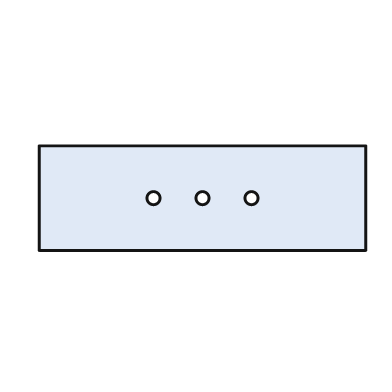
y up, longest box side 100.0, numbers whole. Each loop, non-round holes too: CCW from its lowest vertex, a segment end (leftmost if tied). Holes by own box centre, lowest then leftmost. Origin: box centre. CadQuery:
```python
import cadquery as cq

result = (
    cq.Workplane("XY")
    .moveTo(-50.0, -16.0)
    .lineTo(50.0, -16.0)
    .lineTo(50.0, 16.0)
    .lineTo(-50.0, 16.0)
    .close()
    .moveTo(-15.0, 0.0)
    .circle(2.0)
    .moveTo(0.0, 0.0)
    .circle(2.0)
    .moveTo(15.0, 0.0)
    .circle(2.0)
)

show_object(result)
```